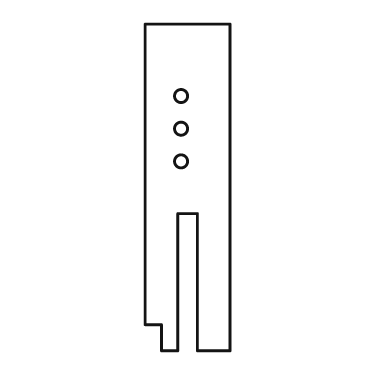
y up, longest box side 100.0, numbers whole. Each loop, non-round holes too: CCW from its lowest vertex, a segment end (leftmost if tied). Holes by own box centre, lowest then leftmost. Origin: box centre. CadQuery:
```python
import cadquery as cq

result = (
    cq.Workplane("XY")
    .moveTo(-8.0, -50.0)
    .lineTo(-3.0, -50.0)
    .lineTo(-3.0, -8.0)
    .lineTo(3.0, -8.0)
    .lineTo(3.0, -50.0)
    .lineTo(13.0, -50.0)
    .lineTo(13.0, 50.0)
    .lineTo(-13.0, 50.0)
    .lineTo(-13.0, -42.0)
    .lineTo(-8.0, -42.0)
    .close()
    .moveTo(-2.0, 8.0)
    .circle(2.0)
    .moveTo(-2.0, 18.0)
    .circle(2.0)
    .moveTo(-2.0, 28.0)
    .circle(2.0)
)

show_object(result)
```